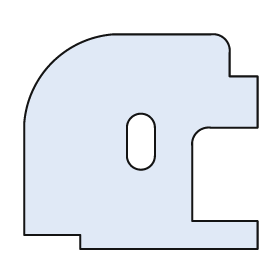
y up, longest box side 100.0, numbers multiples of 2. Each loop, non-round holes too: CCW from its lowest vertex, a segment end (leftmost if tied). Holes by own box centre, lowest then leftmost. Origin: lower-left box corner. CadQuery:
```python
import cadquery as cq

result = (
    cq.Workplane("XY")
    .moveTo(24.0, 0.0)
    .lineTo(100.0, 0.0)
    .lineTo(100.0, 12.0)
    .lineTo(72.0, 12.0)
    .lineTo(72.0, 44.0)
    .threePointArc((74.0, 50.0), (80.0, 52.0))
    .lineTo(100.0, 52.0)
    .lineTo(100.0, 74.0)
    .lineTo(88.0, 74.0)
    .lineTo(88.0, 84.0)
    .threePointArc((86.0, 90.0), (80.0, 92.0))
    .lineTo(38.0, 92.0)
    .threePointArc((12.0, 80.0), (0.0, 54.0))
    .lineTo(0.0, 6.0)
    .lineTo(24.0, 6.0)
    .close()
    .moveTo(44.0, 40.0)
    .threePointArc((50.0, 34.0), (56.0, 40.0))
    .lineTo(56.0, 52.0)
    .threePointArc((50.0, 58.0), (44.0, 52.0))
    .close()
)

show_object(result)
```